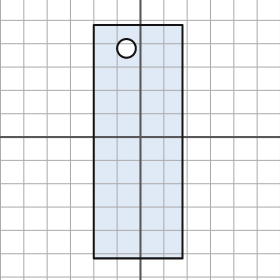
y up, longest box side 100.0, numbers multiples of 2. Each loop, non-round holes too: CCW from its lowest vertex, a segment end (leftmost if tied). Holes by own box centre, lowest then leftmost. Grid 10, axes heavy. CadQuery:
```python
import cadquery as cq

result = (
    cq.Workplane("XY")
    .moveTo(-20.0, -52.0)
    .lineTo(18.0, -52.0)
    .lineTo(18.0, 48.0)
    .lineTo(-20.0, 48.0)
    .close()
    .moveTo(-6.0, 38.0)
    .circle(4.0)
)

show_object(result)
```